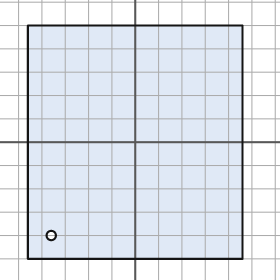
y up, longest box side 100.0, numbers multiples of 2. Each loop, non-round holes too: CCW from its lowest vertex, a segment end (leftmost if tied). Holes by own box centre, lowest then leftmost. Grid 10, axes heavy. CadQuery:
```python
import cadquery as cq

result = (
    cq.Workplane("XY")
    .moveTo(-46.0, -50.0)
    .lineTo(46.0, -50.0)
    .lineTo(46.0, 50.0)
    .lineTo(-46.0, 50.0)
    .close()
    .moveTo(-36.0, -40.0)
    .circle(2.0)
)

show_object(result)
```